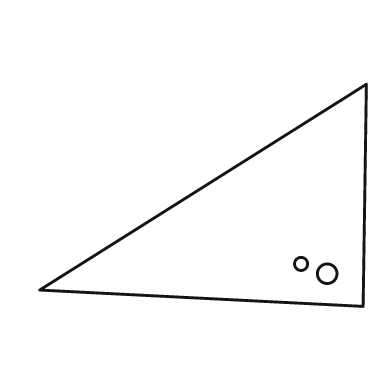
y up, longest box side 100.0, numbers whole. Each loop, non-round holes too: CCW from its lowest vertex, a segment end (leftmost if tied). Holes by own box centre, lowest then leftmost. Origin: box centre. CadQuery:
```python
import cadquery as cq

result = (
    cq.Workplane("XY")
    .moveTo(49.0, -34.0)
    .lineTo(50.0, 34.0)
    .lineTo(-50.0, -29.0)
    .close()
    .moveTo(38.0, -24.0)
    .circle(3.0)
    .moveTo(30.0, -21.0)
    .circle(2.0)
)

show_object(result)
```